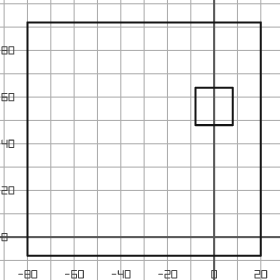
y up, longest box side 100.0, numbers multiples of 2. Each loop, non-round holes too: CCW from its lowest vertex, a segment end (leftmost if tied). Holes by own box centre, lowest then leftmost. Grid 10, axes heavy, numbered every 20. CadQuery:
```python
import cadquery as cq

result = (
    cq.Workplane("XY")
    .moveTo(-80.0, -8.0)
    .lineTo(20.0, -8.0)
    .lineTo(20.0, 92.0)
    .lineTo(-80.0, 92.0)
    .close()
    .moveTo(-8.0, 48.0)
    .lineTo(8.0, 48.0)
    .lineTo(8.0, 64.0)
    .lineTo(-8.0, 64.0)
    .close()
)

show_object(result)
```